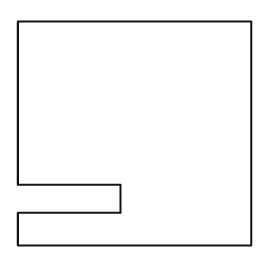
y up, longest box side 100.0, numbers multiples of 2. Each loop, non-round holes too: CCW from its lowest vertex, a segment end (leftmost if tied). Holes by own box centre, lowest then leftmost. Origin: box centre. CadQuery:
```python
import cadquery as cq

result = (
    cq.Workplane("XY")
    .moveTo(-50.0, -48.0)
    .lineTo(50.0, -48.0)
    .lineTo(50.0, 48.0)
    .lineTo(-50.0, 48.0)
    .lineTo(-50.0, -22.0)
    .lineTo(-6.0, -22.0)
    .lineTo(-6.0, -34.0)
    .lineTo(-50.0, -34.0)
    .close()
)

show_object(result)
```